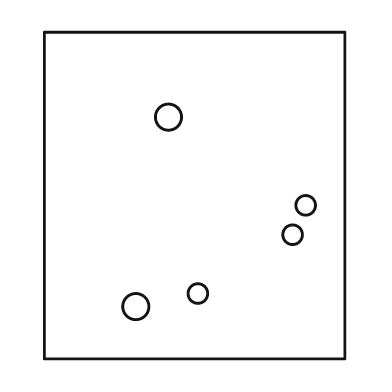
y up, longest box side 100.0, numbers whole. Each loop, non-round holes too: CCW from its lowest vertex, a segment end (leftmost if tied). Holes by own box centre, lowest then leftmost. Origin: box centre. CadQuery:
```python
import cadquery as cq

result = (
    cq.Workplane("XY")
    .moveTo(-46.0, -50.0)
    .lineTo(46.0, -50.0)
    .lineTo(46.0, 50.0)
    .lineTo(-46.0, 50.0)
    .close()
    .moveTo(-18.0, -34.0)
    .circle(4.0)
    .moveTo(1.0, -30.0)
    .circle(3.0)
    .moveTo(30.0, -12.0)
    .circle(3.0)
    .moveTo(34.0, -3.0)
    .circle(3.0)
    .moveTo(-8.0, 24.0)
    .circle(4.0)
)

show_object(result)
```